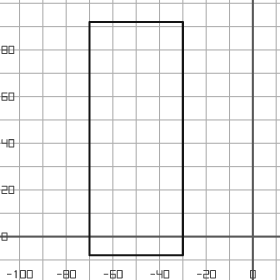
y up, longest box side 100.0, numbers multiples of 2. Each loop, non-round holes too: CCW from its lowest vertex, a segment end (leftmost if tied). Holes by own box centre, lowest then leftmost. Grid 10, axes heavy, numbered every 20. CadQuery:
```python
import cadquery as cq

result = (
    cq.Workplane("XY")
    .moveTo(-70.0, -8.0)
    .lineTo(-30.0, -8.0)
    .lineTo(-30.0, 92.0)
    .lineTo(-70.0, 92.0)
    .close()
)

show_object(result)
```